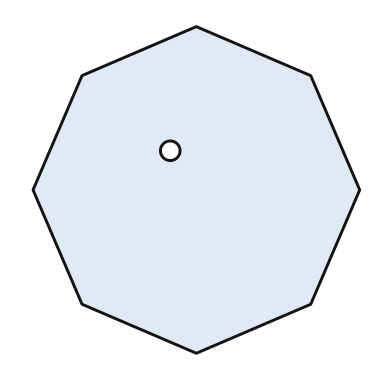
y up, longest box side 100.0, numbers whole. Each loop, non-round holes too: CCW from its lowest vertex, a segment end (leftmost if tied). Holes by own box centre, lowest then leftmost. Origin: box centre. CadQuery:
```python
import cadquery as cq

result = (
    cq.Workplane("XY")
    .moveTo(0.0, -50.0)
    .lineTo(35.0, -35.0)
    .lineTo(50.0, 0.0)
    .lineTo(35.0, 35.0)
    .lineTo(0.0, 50.0)
    .lineTo(-35.0, 35.0)
    .lineTo(-50.0, 0.0)
    .lineTo(-35.0, -35.0)
    .close()
    .moveTo(-8.0, 12.0)
    .circle(3.0)
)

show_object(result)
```